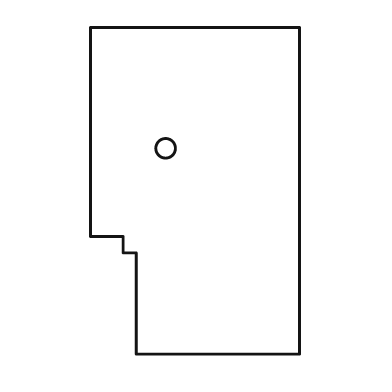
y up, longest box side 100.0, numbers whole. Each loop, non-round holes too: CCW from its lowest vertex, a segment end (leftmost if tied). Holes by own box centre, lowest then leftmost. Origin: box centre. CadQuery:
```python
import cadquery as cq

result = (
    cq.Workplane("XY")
    .moveTo(-18.0, -50.0)
    .lineTo(32.0, -50.0)
    .lineTo(32.0, 50.0)
    .lineTo(-32.0, 50.0)
    .lineTo(-32.0, -14.0)
    .lineTo(-22.0, -14.0)
    .lineTo(-22.0, -19.0)
    .lineTo(-18.0, -19.0)
    .close()
    .moveTo(-9.0, 13.0)
    .circle(3.0)
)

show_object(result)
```